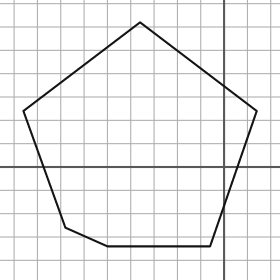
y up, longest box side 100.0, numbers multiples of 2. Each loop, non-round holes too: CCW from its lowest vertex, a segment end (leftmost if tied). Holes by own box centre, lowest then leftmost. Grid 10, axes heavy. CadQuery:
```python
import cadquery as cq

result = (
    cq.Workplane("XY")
    .moveTo(-50.0, -34.0)
    .lineTo(-6.0, -34.0)
    .lineTo(14.0, 24.0)
    .lineTo(-36.0, 62.0)
    .lineTo(-86.0, 24.0)
    .lineTo(-68.0, -26.0)
    .close()
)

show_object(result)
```